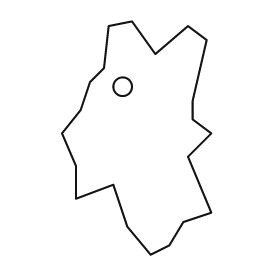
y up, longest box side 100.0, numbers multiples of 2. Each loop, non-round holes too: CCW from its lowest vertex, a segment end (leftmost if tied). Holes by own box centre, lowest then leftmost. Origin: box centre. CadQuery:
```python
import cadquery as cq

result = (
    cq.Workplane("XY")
    .moveTo(6.0, -50.0)
    .lineTo(14.0, -46.0)
    .lineTo(20.0, -36.0)
    .lineTo(32.0, -32.0)
    .lineTo(22.0, -8.0)
    .lineTo(32.0, 2.0)
    .lineTo(24.0, 8.0)
    .lineTo(24.0, 16.0)
    .lineTo(30.0, 42.0)
    .lineTo(22.0, 48.0)
    .lineTo(8.0, 36.0)
    .lineTo(-2.0, 50.0)
    .lineTo(-12.0, 48.0)
    .lineTo(-14.0, 30.0)
    .lineTo(-20.0, 24.0)
    .lineTo(-24.0, 12.0)
    .lineTo(-32.0, 2.0)
    .lineTo(-26.0, -12.0)
    .lineTo(-26.0, -26.0)
    .lineTo(-10.0, -20.0)
    .lineTo(-4.0, -38.0)
    .close()
    .moveTo(-6.0, 22.0)
    .circle(4.0)
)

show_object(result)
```